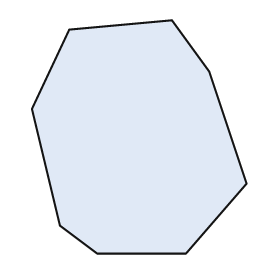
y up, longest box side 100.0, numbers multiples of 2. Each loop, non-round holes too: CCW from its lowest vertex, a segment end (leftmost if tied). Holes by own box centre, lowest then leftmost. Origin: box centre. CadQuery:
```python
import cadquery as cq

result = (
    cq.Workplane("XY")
    .moveTo(-18.0, -50.0)
    .lineTo(20.0, -50.0)
    .lineTo(46.0, -20.0)
    .lineTo(30.0, 28.0)
    .lineTo(14.0, 50.0)
    .lineTo(-30.0, 46.0)
    .lineTo(-46.0, 12.0)
    .lineTo(-34.0, -38.0)
    .close()
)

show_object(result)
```